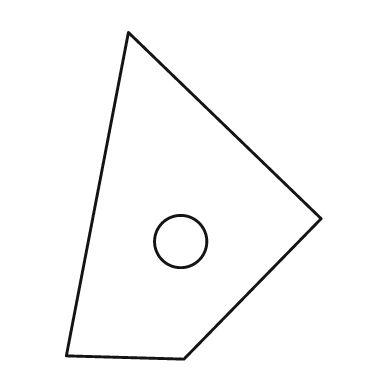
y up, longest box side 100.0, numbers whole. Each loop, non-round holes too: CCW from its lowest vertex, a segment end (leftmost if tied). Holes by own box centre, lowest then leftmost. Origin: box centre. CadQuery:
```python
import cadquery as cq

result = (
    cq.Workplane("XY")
    .moveTo(-3.0, -50.0)
    .lineTo(39.0, -7.0)
    .lineTo(-20.0, 50.0)
    .lineTo(-39.0, -49.0)
    .close()
    .moveTo(-4.0, -14.0)
    .circle(8.0)
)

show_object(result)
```